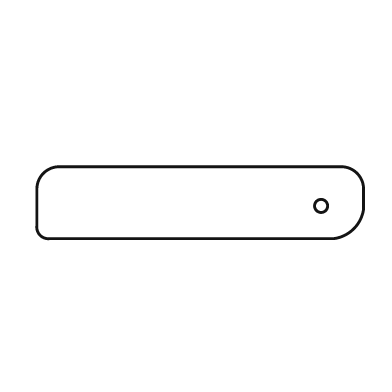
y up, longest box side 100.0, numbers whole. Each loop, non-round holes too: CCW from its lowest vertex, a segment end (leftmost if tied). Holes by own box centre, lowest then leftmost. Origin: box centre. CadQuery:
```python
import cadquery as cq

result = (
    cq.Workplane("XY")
    .moveTo(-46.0, -11.0)
    .lineTo(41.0, -11.0)
    .threePointArc((47.0, -8.0), (50.0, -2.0))
    .lineTo(50.0, 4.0)
    .threePointArc((48.0, 9.0), (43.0, 11.0))
    .lineTo(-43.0, 11.0)
    .threePointArc((-48.0, 9.0), (-50.0, 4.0))
    .lineTo(-50.0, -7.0)
    .threePointArc((-49.0, -10.0), (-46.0, -11.0))
    .close()
    .moveTo(37.0, -1.0)
    .circle(2.0)
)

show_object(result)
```